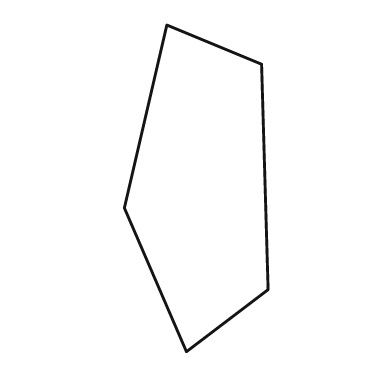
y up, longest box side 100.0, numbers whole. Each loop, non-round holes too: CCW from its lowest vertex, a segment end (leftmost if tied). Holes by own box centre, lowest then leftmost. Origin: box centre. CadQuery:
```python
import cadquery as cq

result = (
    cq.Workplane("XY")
    .moveTo(-3.0, -50.0)
    .lineTo(22.0, -31.0)
    .lineTo(20.0, 38.0)
    .lineTo(-9.0, 50.0)
    .lineTo(-22.0, -6.0)
    .close()
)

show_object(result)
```